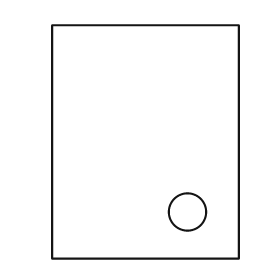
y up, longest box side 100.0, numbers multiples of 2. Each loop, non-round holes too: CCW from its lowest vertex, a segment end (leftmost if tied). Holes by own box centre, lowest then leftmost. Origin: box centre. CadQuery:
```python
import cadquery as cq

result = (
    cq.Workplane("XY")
    .moveTo(-40.0, -50.0)
    .lineTo(40.0, -50.0)
    .lineTo(40.0, 50.0)
    .lineTo(-40.0, 50.0)
    .close()
    .moveTo(18.0, -30.0)
    .circle(8.0)
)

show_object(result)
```